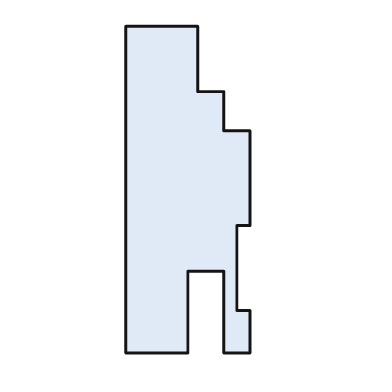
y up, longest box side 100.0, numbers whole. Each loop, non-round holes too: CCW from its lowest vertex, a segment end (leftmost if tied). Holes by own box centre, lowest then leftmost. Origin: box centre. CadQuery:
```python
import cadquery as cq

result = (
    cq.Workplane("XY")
    .moveTo(-19.0, -50.0)
    .lineTo(0.0, -50.0)
    .lineTo(0.0, -25.0)
    .lineTo(11.0, -25.0)
    .lineTo(11.0, -50.0)
    .lineTo(19.0, -50.0)
    .lineTo(19.0, -37.0)
    .lineTo(15.0, -37.0)
    .lineTo(15.0, -11.0)
    .lineTo(19.0, -11.0)
    .lineTo(19.0, 18.0)
    .lineTo(11.0, 18.0)
    .lineTo(11.0, 30.0)
    .lineTo(3.0, 30.0)
    .lineTo(3.0, 50.0)
    .lineTo(-19.0, 50.0)
    .close()
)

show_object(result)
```